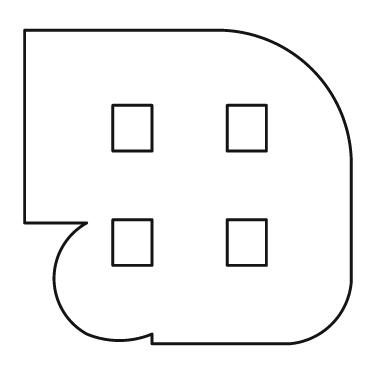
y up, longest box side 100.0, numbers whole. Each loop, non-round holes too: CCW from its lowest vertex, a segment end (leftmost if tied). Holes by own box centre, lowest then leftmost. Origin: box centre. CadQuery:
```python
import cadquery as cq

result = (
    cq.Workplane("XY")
    .moveTo(-11.0, -48.0)
    .lineTo(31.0, -48.0)
    .threePointArc((44.0, -42.0), (50.0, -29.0))
    .lineTo(50.0, 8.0)
    .threePointArc((38.0, 36.0), (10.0, 48.0))
    .lineTo(-50.0, 48.0)
    .lineTo(-50.0, -11.0)
    .lineTo(-31.0, -11.0)
    .threePointArc((-41.0, -28.0), (-31.0, -45.0))
    .threePointArc((-21.0, -47.0), (-11.0, -45.0))
    .close()
    .moveTo(-23.0, -24.0)
    .lineTo(-11.0, -24.0)
    .lineTo(-11.0, -10.0)
    .lineTo(-23.0, -10.0)
    .close()
    .moveTo(12.0, -24.0)
    .lineTo(24.0, -24.0)
    .lineTo(24.0, -10.0)
    .lineTo(12.0, -10.0)
    .close()
    .moveTo(-23.0, 11.0)
    .lineTo(-11.0, 11.0)
    .lineTo(-11.0, 25.0)
    .lineTo(-23.0, 25.0)
    .close()
    .moveTo(12.0, 11.0)
    .lineTo(24.0, 11.0)
    .lineTo(24.0, 25.0)
    .lineTo(12.0, 25.0)
    .close()
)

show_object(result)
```